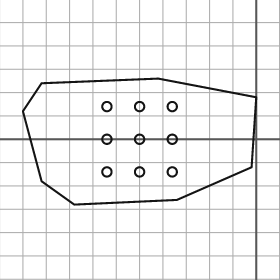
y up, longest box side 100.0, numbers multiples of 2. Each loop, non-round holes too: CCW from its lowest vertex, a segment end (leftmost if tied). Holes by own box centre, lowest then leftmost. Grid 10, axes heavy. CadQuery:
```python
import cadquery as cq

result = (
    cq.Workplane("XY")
    .moveTo(-78.0, -28.0)
    .lineTo(-34.0, -26.0)
    .lineTo(-2.0, -12.0)
    .lineTo(0.0, 18.0)
    .lineTo(-42.0, 26.0)
    .lineTo(-92.0, 24.0)
    .lineTo(-100.0, 12.0)
    .lineTo(-92.0, -18.0)
    .close()
    .moveTo(-64.0, -14.0)
    .circle(2.0)
    .moveTo(-50.0, -14.0)
    .circle(2.0)
    .moveTo(-36.0, -14.0)
    .circle(2.0)
    .moveTo(-64.0, 0.0)
    .circle(2.0)
    .moveTo(-50.0, 0.0)
    .circle(2.0)
    .moveTo(-36.0, 0.0)
    .circle(2.0)
    .moveTo(-64.0, 14.0)
    .circle(2.0)
    .moveTo(-50.0, 14.0)
    .circle(2.0)
    .moveTo(-36.0, 14.0)
    .circle(2.0)
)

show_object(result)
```